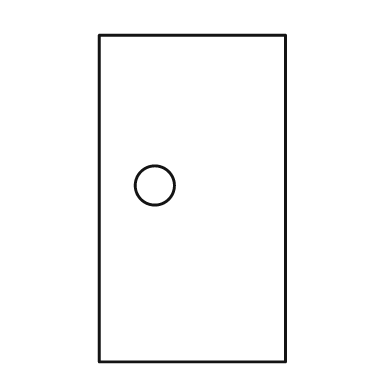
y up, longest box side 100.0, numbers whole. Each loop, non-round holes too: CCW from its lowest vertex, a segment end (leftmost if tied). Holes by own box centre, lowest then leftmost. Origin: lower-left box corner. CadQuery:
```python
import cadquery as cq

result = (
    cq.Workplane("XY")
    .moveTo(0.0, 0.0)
    .lineTo(57.0, 0.0)
    .lineTo(57.0, 100.0)
    .lineTo(0.0, 100.0)
    .close()
    .moveTo(17.0, 54.0)
    .circle(6.0)
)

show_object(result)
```